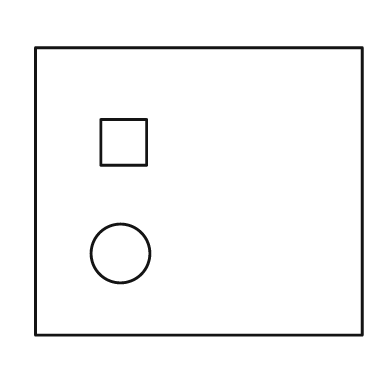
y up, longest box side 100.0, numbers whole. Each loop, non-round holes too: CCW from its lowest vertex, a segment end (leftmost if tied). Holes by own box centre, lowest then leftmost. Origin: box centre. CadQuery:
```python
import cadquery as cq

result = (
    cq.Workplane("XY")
    .moveTo(-50.0, -44.0)
    .lineTo(50.0, -44.0)
    .lineTo(50.0, 44.0)
    .lineTo(-50.0, 44.0)
    .close()
    .moveTo(-24.0, -19.0)
    .circle(9.0)
    .moveTo(-30.0, 8.0)
    .lineTo(-16.0, 8.0)
    .lineTo(-16.0, 22.0)
    .lineTo(-30.0, 22.0)
    .close()
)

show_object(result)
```